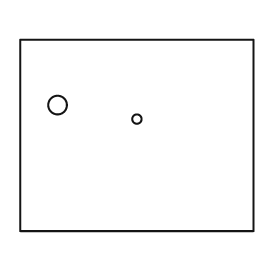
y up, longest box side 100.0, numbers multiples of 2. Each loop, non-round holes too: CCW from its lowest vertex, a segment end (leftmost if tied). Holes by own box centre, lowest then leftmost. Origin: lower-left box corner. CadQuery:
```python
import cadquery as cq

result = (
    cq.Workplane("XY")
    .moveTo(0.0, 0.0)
    .lineTo(100.0, 0.0)
    .lineTo(100.0, 82.0)
    .lineTo(0.0, 82.0)
    .close()
    .moveTo(50.0, 48.0)
    .circle(2.0)
    .moveTo(16.0, 54.0)
    .circle(4.0)
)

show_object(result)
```